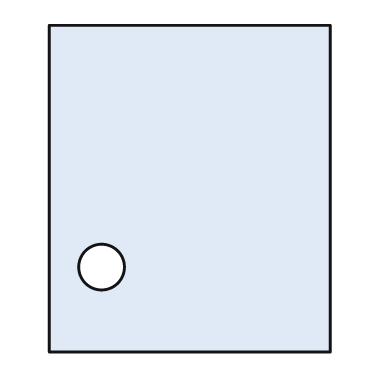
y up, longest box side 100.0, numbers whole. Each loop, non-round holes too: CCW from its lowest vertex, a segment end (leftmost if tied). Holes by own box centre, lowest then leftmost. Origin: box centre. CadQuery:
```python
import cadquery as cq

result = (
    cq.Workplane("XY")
    .moveTo(-43.0, -50.0)
    .lineTo(43.0, -50.0)
    .lineTo(43.0, 50.0)
    .lineTo(-43.0, 50.0)
    .close()
    .moveTo(-27.0, -24.0)
    .circle(7.0)
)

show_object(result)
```